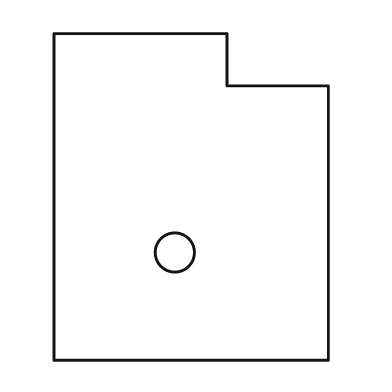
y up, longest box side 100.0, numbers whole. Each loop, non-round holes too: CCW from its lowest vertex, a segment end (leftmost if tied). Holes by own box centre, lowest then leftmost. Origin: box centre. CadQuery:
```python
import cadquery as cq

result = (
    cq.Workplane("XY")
    .moveTo(-42.0, -50.0)
    .lineTo(42.0, -50.0)
    .lineTo(42.0, 34.0)
    .lineTo(11.0, 34.0)
    .lineTo(11.0, 50.0)
    .lineTo(-42.0, 50.0)
    .close()
    .moveTo(-5.0, -17.0)
    .circle(6.0)
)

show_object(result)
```